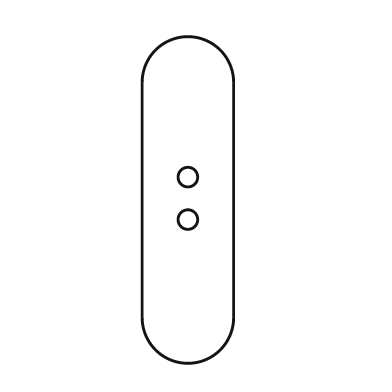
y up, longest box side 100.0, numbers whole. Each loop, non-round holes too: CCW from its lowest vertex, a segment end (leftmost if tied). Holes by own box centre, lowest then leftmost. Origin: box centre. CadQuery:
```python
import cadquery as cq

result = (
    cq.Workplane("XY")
    .moveTo(-14.0, -36.0)
    .threePointArc((0.0, -50.0), (14.0, -36.0))
    .lineTo(14.0, 36.0)
    .threePointArc((0.0, 50.0), (-14.0, 36.0))
    .close()
    .moveTo(0.0, -6.0)
    .circle(3.0)
    .moveTo(0.0, 7.0)
    .circle(3.0)
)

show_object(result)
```